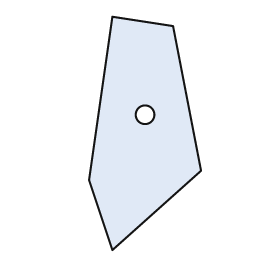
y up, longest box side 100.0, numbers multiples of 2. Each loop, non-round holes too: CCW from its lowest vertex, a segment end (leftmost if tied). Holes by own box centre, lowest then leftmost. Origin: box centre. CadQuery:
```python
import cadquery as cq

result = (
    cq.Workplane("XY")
    .moveTo(-14.0, -50.0)
    .lineTo(24.0, -16.0)
    .lineTo(12.0, 46.0)
    .lineTo(-14.0, 50.0)
    .lineTo(-24.0, -20.0)
    .close()
    .moveTo(0.0, 8.0)
    .circle(4.0)
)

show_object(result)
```